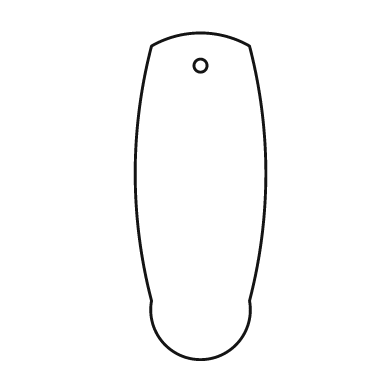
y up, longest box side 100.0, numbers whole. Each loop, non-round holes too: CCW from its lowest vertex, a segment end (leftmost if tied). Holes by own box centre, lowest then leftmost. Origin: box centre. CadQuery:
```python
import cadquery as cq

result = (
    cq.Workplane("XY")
    .moveTo(-15.0, -32.0)
    .threePointArc((0.0, -50.0), (15.0, -32.0))
    .threePointArc((20.0, 7.0), (15.0, 46.0))
    .threePointArc((0.0, 50.0), (-15.0, 46.0))
    .threePointArc((-20.0, 7.0), (-15.0, -32.0))
    .close()
    .moveTo(0.0, 40.0)
    .circle(2.0)
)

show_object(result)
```